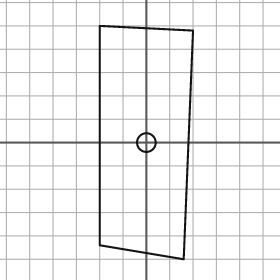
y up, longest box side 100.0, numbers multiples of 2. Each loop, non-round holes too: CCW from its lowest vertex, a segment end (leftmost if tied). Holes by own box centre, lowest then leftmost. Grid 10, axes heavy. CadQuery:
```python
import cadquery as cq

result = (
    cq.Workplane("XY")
    .moveTo(16.0, -50.0)
    .lineTo(20.0, 48.0)
    .lineTo(-20.0, 50.0)
    .lineTo(-20.0, -44.0)
    .close()
    .moveTo(0.0, 0.0)
    .circle(4.0)
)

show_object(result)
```